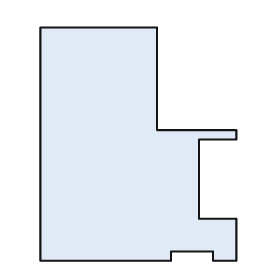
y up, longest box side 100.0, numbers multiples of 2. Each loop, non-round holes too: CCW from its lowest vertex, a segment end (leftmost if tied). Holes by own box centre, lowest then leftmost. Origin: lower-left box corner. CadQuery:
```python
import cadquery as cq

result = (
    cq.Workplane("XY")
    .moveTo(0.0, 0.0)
    .lineTo(56.0, 0.0)
    .lineTo(56.0, 4.0)
    .lineTo(74.0, 4.0)
    .lineTo(74.0, 0.0)
    .lineTo(84.0, 0.0)
    .lineTo(84.0, 18.0)
    .lineTo(68.0, 18.0)
    .lineTo(68.0, 52.0)
    .lineTo(84.0, 52.0)
    .lineTo(84.0, 56.0)
    .lineTo(50.0, 56.0)
    .lineTo(50.0, 100.0)
    .lineTo(0.0, 100.0)
    .close()
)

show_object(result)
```